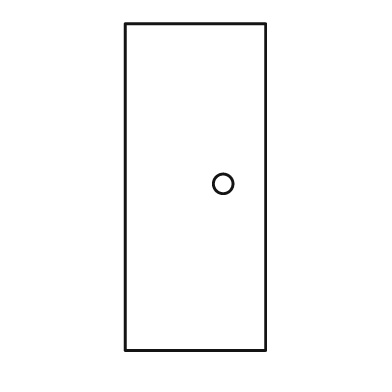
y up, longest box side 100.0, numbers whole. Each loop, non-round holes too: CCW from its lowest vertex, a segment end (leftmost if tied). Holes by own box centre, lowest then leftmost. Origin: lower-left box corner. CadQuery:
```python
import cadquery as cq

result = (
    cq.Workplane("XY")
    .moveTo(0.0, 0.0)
    .lineTo(43.0, 0.0)
    .lineTo(43.0, 100.0)
    .lineTo(0.0, 100.0)
    .close()
    .moveTo(30.0, 51.0)
    .circle(3.0)
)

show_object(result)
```